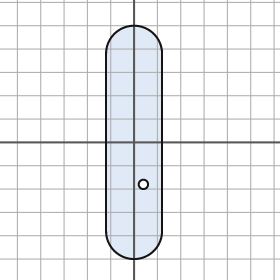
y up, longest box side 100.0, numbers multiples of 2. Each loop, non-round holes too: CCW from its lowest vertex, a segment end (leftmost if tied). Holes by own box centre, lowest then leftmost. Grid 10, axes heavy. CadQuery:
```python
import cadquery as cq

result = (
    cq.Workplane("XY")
    .moveTo(-12.0, -38.0)
    .threePointArc((0.0, -50.0), (12.0, -38.0))
    .lineTo(12.0, 38.0)
    .threePointArc((0.0, 50.0), (-12.0, 38.0))
    .close()
    .moveTo(4.0, -18.0)
    .circle(2.0)
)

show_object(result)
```